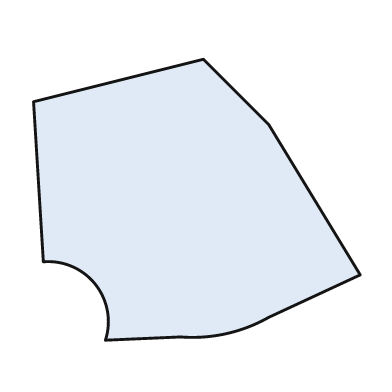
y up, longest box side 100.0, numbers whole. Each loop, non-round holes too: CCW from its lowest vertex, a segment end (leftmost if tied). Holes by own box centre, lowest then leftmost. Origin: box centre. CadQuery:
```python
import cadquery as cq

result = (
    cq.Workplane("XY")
    .moveTo(-28.0, -43.0)
    .lineTo(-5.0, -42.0)
    .threePointArc((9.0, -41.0), (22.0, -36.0))
    .lineTo(50.0, -23.0)
    .lineTo(22.0, 23.0)
    .lineTo(2.0, 43.0)
    .lineTo(-50.0, 30.0)
    .lineTo(-47.0, -19.0)
    .threePointArc((-31.0, -26.0), (-28.0, -43.0))
    .close()
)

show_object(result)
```